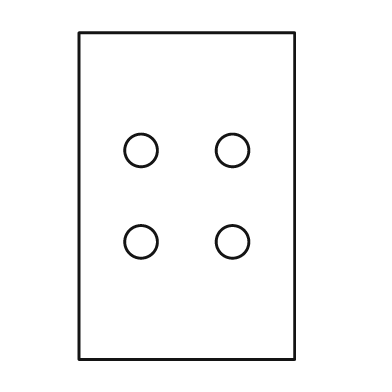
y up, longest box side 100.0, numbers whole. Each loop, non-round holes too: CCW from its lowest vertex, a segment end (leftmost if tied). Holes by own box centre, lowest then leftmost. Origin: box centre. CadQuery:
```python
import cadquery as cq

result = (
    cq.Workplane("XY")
    .moveTo(-33.0, -50.0)
    .lineTo(33.0, -50.0)
    .lineTo(33.0, 50.0)
    .lineTo(-33.0, 50.0)
    .close()
    .moveTo(-14.0, -14.0)
    .circle(5.0)
    .moveTo(14.0, -14.0)
    .circle(5.0)
    .moveTo(-14.0, 14.0)
    .circle(5.0)
    .moveTo(14.0, 14.0)
    .circle(5.0)
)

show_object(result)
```